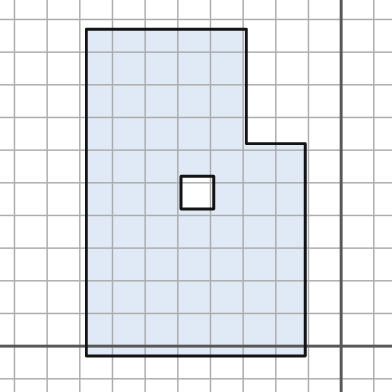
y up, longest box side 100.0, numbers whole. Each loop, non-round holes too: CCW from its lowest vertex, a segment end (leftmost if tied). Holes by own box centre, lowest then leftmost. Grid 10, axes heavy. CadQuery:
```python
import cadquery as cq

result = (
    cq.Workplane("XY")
    .moveTo(-78.0, -3.0)
    .lineTo(-11.0, -3.0)
    .lineTo(-11.0, 62.0)
    .lineTo(-29.0, 62.0)
    .lineTo(-29.0, 97.0)
    .lineTo(-78.0, 97.0)
    .close()
    .moveTo(-49.0, 42.0)
    .lineTo(-39.0, 42.0)
    .lineTo(-39.0, 52.0)
    .lineTo(-49.0, 52.0)
    .close()
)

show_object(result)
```